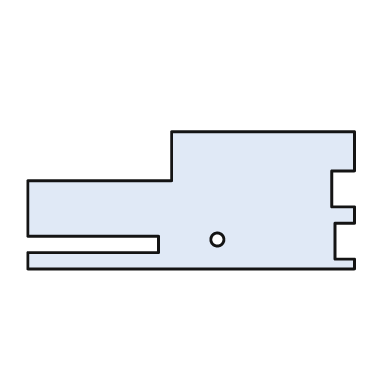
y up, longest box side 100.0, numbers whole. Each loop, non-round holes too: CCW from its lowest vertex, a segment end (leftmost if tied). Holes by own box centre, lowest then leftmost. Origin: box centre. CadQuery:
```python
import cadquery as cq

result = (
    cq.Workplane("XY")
    .moveTo(-50.0, -21.0)
    .lineTo(50.0, -21.0)
    .lineTo(50.0, -18.0)
    .lineTo(44.0, -18.0)
    .lineTo(44.0, -7.0)
    .lineTo(50.0, -7.0)
    .lineTo(50.0, -2.0)
    .lineTo(43.0, -2.0)
    .lineTo(43.0, 9.0)
    .lineTo(50.0, 9.0)
    .lineTo(50.0, 21.0)
    .lineTo(-6.0, 21.0)
    .lineTo(-6.0, 6.0)
    .lineTo(-50.0, 6.0)
    .lineTo(-50.0, -11.0)
    .lineTo(-10.0, -11.0)
    .lineTo(-10.0, -16.0)
    .lineTo(-50.0, -16.0)
    .close()
    .moveTo(8.0, -12.0)
    .circle(2.0)
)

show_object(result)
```